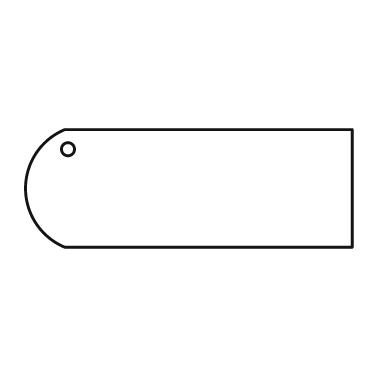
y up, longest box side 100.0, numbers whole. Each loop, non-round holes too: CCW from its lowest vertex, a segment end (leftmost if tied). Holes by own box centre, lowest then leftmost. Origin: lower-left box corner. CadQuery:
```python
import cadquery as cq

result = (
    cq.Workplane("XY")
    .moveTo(12.0, 0.0)
    .lineTo(100.0, 0.0)
    .lineTo(100.0, 36.0)
    .lineTo(12.0, 36.0)
    .threePointArc((0.0, 18.0), (12.0, 0.0))
    .close()
    .moveTo(13.0, 30.0)
    .circle(2.0)
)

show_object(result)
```